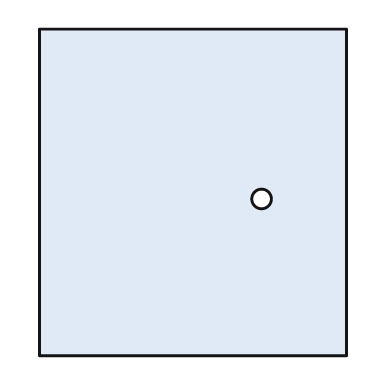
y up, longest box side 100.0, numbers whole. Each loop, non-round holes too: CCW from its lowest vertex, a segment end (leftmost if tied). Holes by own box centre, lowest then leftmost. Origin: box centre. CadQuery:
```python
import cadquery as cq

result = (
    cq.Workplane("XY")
    .moveTo(-47.0, -50.0)
    .lineTo(47.0, -50.0)
    .lineTo(47.0, 50.0)
    .lineTo(-47.0, 50.0)
    .close()
    .moveTo(21.0, -2.0)
    .circle(3.0)
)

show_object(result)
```